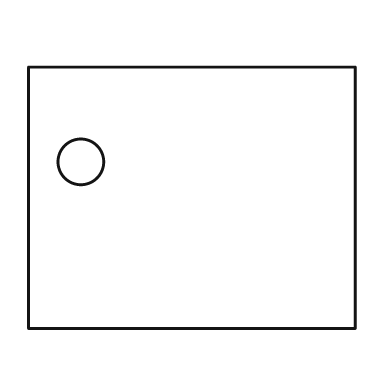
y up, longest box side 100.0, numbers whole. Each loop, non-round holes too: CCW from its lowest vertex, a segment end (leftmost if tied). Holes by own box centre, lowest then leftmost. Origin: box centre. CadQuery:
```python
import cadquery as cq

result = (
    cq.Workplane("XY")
    .moveTo(-50.0, -40.0)
    .lineTo(50.0, -40.0)
    .lineTo(50.0, 40.0)
    .lineTo(-50.0, 40.0)
    .close()
    .moveTo(-34.0, 11.0)
    .circle(7.0)
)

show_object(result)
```